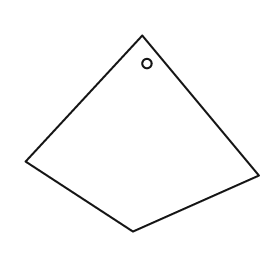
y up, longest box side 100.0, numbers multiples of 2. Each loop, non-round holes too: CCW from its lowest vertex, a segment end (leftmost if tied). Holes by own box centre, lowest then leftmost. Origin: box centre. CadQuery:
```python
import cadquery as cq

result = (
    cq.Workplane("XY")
    .moveTo(-4.0, -42.0)
    .lineTo(50.0, -18.0)
    .lineTo(0.0, 42.0)
    .lineTo(-50.0, -12.0)
    .close()
    .moveTo(2.0, 30.0)
    .circle(2.0)
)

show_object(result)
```